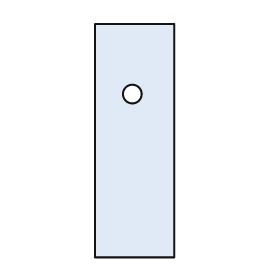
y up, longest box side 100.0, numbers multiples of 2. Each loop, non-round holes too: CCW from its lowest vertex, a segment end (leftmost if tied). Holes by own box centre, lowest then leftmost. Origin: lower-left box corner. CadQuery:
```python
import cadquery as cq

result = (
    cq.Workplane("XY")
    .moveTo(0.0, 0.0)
    .lineTo(34.0, 0.0)
    .lineTo(34.0, 100.0)
    .lineTo(0.0, 100.0)
    .close()
    .moveTo(16.0, 70.0)
    .circle(4.0)
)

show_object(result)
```